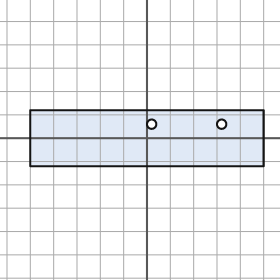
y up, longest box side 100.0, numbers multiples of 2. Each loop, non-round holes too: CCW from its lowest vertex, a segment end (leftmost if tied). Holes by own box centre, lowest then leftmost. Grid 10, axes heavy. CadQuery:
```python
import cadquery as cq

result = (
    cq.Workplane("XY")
    .moveTo(-50.0, -12.0)
    .lineTo(50.0, -12.0)
    .lineTo(50.0, 12.0)
    .lineTo(-50.0, 12.0)
    .close()
    .moveTo(2.0, 6.0)
    .circle(2.0)
    .moveTo(32.0, 6.0)
    .circle(2.0)
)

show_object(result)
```